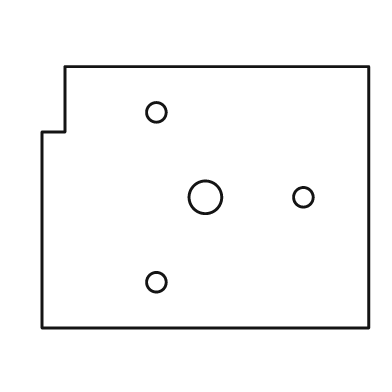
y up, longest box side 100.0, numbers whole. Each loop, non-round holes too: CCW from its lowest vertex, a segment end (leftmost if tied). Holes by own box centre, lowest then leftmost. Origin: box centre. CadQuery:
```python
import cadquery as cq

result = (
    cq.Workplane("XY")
    .moveTo(-50.0, -40.0)
    .lineTo(50.0, -40.0)
    .lineTo(50.0, 40.0)
    .lineTo(-43.0, 40.0)
    .lineTo(-43.0, 20.0)
    .lineTo(-50.0, 20.0)
    .close()
    .moveTo(-15.0, -26.0)
    .circle(3.0)
    .moveTo(0.0, 0.0)
    .circle(5.0)
    .moveTo(30.0, 0.0)
    .circle(3.0)
    .moveTo(-15.0, 26.0)
    .circle(3.0)
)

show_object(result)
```